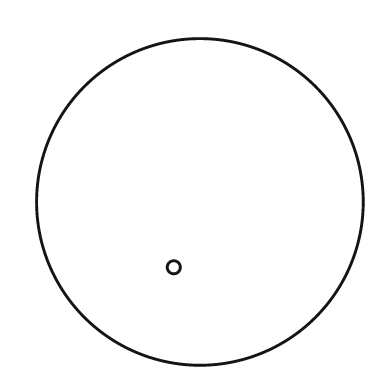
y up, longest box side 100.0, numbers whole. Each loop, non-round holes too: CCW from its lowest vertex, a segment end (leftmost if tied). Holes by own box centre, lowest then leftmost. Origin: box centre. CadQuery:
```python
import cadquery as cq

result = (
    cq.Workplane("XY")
    .moveTo(0.0, 0.0)
    .circle(50.0)
    .moveTo(-8.0, -20.0)
    .circle(2.0)
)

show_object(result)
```